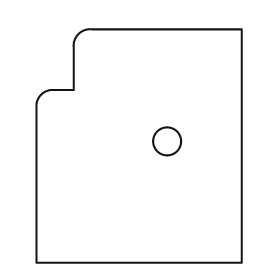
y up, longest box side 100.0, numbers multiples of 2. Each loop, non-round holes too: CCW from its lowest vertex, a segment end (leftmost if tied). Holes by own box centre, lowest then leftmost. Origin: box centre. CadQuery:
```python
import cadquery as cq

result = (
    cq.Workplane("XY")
    .moveTo(-44.0, -50.0)
    .lineTo(44.0, -50.0)
    .lineTo(44.0, 50.0)
    .lineTo(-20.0, 50.0)
    .threePointArc((-26.0, 48.0), (-28.0, 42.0))
    .lineTo(-28.0, 24.0)
    .lineTo(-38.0, 24.0)
    .threePointArc((-42.0, 22.0), (-44.0, 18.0))
    .close()
    .moveTo(12.0, 2.0)
    .circle(6.0)
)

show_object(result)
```